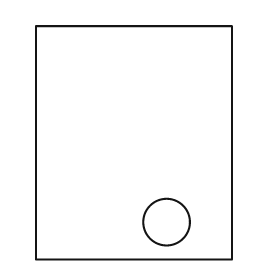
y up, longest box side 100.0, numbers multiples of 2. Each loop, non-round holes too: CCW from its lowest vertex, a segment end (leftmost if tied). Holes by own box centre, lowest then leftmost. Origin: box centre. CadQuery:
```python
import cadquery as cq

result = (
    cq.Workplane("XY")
    .moveTo(-42.0, -50.0)
    .lineTo(42.0, -50.0)
    .lineTo(42.0, 50.0)
    .lineTo(-42.0, 50.0)
    .close()
    .moveTo(14.0, -34.0)
    .circle(10.0)
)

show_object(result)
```